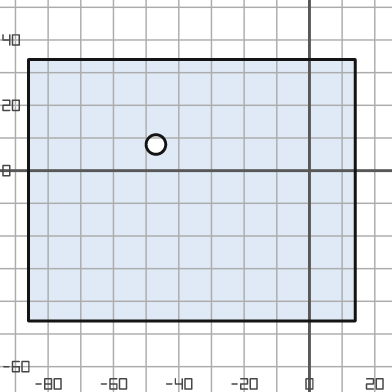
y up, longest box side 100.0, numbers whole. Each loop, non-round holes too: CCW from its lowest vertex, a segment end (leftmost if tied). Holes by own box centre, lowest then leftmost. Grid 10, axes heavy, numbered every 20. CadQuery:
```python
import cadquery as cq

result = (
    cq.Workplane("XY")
    .moveTo(-86.0, -46.0)
    .lineTo(14.0, -46.0)
    .lineTo(14.0, 34.0)
    .lineTo(-86.0, 34.0)
    .close()
    .moveTo(-47.0, 8.0)
    .circle(3.0)
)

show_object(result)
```